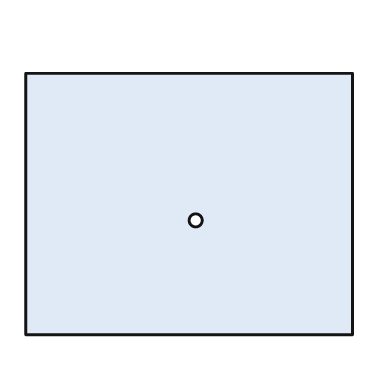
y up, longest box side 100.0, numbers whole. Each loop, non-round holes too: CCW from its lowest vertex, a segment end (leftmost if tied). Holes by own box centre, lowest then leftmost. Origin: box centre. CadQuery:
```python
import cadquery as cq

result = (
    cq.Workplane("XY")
    .moveTo(-50.0, -40.0)
    .lineTo(50.0, -40.0)
    .lineTo(50.0, 40.0)
    .lineTo(-50.0, 40.0)
    .close()
    .moveTo(2.0, -5.0)
    .circle(2.0)
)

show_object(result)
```